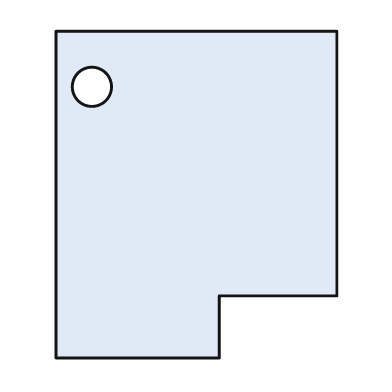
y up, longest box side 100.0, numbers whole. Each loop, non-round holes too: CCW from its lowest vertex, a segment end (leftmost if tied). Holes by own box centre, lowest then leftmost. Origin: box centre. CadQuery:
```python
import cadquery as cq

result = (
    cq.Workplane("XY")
    .moveTo(-43.0, -50.0)
    .lineTo(7.0, -50.0)
    .lineTo(7.0, -31.0)
    .lineTo(43.0, -31.0)
    .lineTo(43.0, 50.0)
    .lineTo(-43.0, 50.0)
    .close()
    .moveTo(-32.0, 33.0)
    .circle(6.0)
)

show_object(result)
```